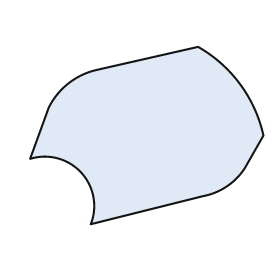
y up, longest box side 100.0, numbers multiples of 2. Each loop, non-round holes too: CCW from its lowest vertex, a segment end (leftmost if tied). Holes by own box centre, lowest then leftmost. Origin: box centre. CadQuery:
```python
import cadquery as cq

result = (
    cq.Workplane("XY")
    .moveTo(-24.0, -38.0)
    .lineTo(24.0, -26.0)
    .threePointArc((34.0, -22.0), (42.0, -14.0))
    .lineTo(50.0, 0.0)
    .threePointArc((40.0, 22.0), (22.0, 38.0))
    .lineTo(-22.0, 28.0)
    .threePointArc((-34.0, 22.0), (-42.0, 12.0))
    .lineTo(-50.0, -10.0)
    .threePointArc((-28.0, -16.0), (-24.0, -38.0))
    .close()
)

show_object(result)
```